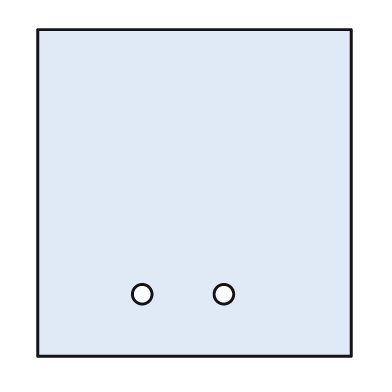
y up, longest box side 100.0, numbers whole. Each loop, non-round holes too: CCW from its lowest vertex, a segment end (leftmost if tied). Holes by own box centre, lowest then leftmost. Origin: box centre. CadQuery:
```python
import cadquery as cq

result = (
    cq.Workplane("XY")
    .moveTo(-48.0, -50.0)
    .lineTo(48.0, -50.0)
    .lineTo(48.0, 50.0)
    .lineTo(-48.0, 50.0)
    .close()
    .moveTo(-16.0, -31.0)
    .circle(3.0)
    .moveTo(9.0, -31.0)
    .circle(3.0)
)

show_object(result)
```